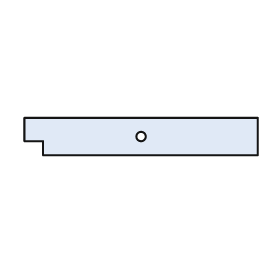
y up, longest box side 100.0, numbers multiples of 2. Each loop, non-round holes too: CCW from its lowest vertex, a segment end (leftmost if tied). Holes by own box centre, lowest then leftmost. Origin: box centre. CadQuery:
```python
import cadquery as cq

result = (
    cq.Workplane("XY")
    .moveTo(-42.0, -8.0)
    .lineTo(50.0, -8.0)
    .lineTo(50.0, 8.0)
    .lineTo(-50.0, 8.0)
    .lineTo(-50.0, -2.0)
    .lineTo(-42.0, -2.0)
    .close()
    .moveTo(0.0, 0.0)
    .circle(2.0)
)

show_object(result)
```